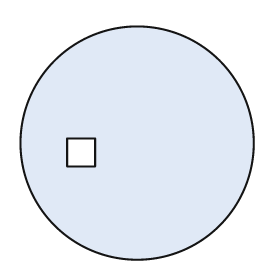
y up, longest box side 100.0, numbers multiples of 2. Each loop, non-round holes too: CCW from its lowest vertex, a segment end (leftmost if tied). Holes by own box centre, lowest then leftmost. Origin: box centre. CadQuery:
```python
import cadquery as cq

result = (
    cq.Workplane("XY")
    .moveTo(0.0, 0.0)
    .circle(50.0)
    .moveTo(-30.0, -10.0)
    .lineTo(-18.0, -10.0)
    .lineTo(-18.0, 2.0)
    .lineTo(-30.0, 2.0)
    .close()
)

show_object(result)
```